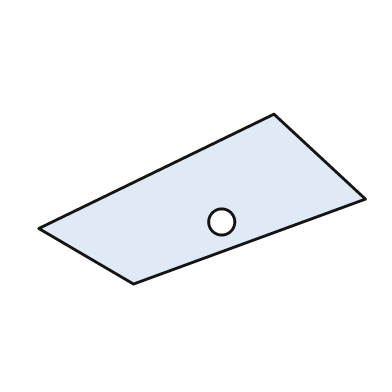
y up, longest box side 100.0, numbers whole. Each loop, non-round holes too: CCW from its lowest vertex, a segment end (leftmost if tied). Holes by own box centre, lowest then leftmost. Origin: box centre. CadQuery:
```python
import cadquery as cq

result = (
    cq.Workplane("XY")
    .moveTo(-21.0, -26.0)
    .lineTo(50.0, 0.0)
    .lineTo(22.0, 26.0)
    .lineTo(-50.0, -9.0)
    .close()
    .moveTo(6.0, -7.0)
    .circle(4.0)
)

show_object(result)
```